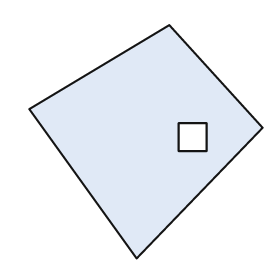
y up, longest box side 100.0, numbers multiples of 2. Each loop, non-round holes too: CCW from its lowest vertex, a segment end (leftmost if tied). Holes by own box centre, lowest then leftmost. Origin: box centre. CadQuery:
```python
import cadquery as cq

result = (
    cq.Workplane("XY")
    .moveTo(-4.0, -50.0)
    .lineTo(50.0, 6.0)
    .lineTo(10.0, 50.0)
    .lineTo(-50.0, 14.0)
    .close()
    .moveTo(14.0, -4.0)
    .lineTo(26.0, -4.0)
    .lineTo(26.0, 8.0)
    .lineTo(14.0, 8.0)
    .close()
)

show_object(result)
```